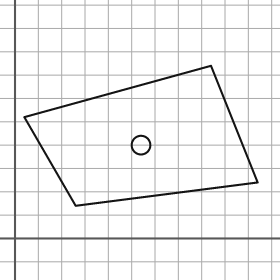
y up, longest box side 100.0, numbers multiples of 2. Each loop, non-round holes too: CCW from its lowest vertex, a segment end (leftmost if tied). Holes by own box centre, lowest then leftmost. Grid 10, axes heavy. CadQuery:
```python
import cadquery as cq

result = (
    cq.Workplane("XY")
    .moveTo(26.0, 14.0)
    .lineTo(104.0, 24.0)
    .lineTo(84.0, 74.0)
    .lineTo(4.0, 52.0)
    .close()
    .moveTo(54.0, 40.0)
    .circle(4.0)
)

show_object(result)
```